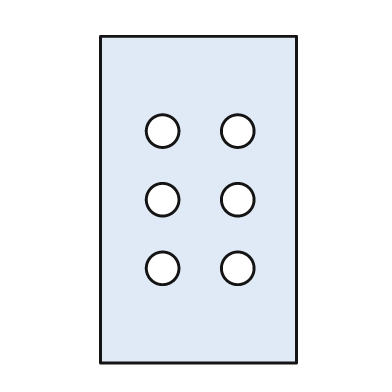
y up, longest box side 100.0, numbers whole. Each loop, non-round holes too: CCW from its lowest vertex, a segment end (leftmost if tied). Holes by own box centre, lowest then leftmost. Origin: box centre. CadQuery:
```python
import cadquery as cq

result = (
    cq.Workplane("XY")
    .moveTo(-30.0, -50.0)
    .lineTo(30.0, -50.0)
    .lineTo(30.0, 50.0)
    .lineTo(-30.0, 50.0)
    .close()
    .moveTo(-11.0, -21.0)
    .circle(5.0)
    .moveTo(12.0, -21.0)
    .circle(5.0)
    .moveTo(-11.0, 0.0)
    .circle(5.0)
    .moveTo(12.0, 0.0)
    .circle(5.0)
    .moveTo(-11.0, 21.0)
    .circle(5.0)
    .moveTo(12.0, 21.0)
    .circle(5.0)
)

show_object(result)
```